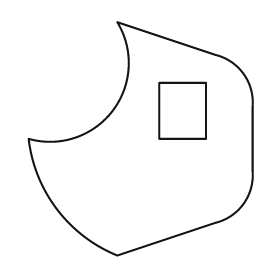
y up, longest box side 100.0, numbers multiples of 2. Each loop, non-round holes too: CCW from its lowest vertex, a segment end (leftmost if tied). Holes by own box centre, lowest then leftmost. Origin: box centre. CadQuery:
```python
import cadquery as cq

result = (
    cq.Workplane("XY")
    .moveTo(-10.0, -50.0)
    .lineTo(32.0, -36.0)
    .threePointArc((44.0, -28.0), (48.0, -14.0))
    .lineTo(48.0, 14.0)
    .threePointArc((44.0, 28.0), (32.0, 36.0))
    .lineTo(-10.0, 50.0)
    .threePointArc((-12.0, 12.0), (-48.0, 0.0))
    .threePointArc((-36.0, -30.0), (-10.0, -50.0))
    .close()
    .moveTo(8.0, 0.0)
    .lineTo(28.0, 0.0)
    .lineTo(28.0, 24.0)
    .lineTo(8.0, 24.0)
    .close()
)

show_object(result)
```